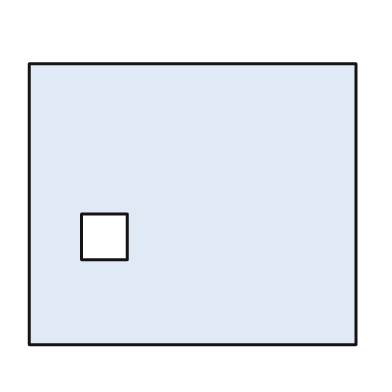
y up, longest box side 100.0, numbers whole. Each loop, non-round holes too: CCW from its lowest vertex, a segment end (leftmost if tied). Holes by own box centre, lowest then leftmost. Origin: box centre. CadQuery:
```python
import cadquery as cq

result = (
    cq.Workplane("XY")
    .moveTo(-50.0, -43.0)
    .lineTo(50.0, -43.0)
    .lineTo(50.0, 43.0)
    .lineTo(-50.0, 43.0)
    .close()
    .moveTo(-34.0, -17.0)
    .lineTo(-20.0, -17.0)
    .lineTo(-20.0, -3.0)
    .lineTo(-34.0, -3.0)
    .close()
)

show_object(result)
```